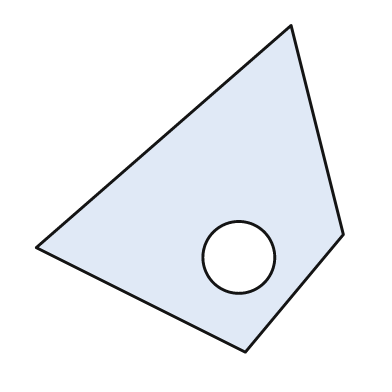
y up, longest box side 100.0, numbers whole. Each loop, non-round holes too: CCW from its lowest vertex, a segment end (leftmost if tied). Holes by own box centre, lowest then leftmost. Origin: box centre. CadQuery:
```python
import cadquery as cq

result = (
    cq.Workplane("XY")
    .moveTo(17.0, -50.0)
    .lineTo(47.0, -14.0)
    .lineTo(31.0, 50.0)
    .lineTo(-47.0, -18.0)
    .close()
    .moveTo(15.0, -21.0)
    .circle(11.0)
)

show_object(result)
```